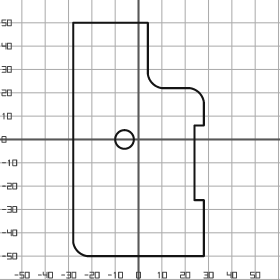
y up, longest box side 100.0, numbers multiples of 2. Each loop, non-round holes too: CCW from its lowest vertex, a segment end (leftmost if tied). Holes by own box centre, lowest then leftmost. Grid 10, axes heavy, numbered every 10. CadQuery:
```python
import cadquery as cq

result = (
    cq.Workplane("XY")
    .moveTo(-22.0, -50.0)
    .lineTo(28.0, -50.0)
    .lineTo(28.0, -26.0)
    .lineTo(24.0, -26.0)
    .lineTo(24.0, 6.0)
    .lineTo(28.0, 6.0)
    .lineTo(28.0, 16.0)
    .threePointArc((26.0, 20.0), (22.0, 22.0))
    .lineTo(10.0, 22.0)
    .threePointArc((6.0, 24.0), (4.0, 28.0))
    .lineTo(4.0, 50.0)
    .lineTo(-28.0, 50.0)
    .lineTo(-28.0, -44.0)
    .threePointArc((-26.0, -48.0), (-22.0, -50.0))
    .close()
    .moveTo(-6.0, 0.0)
    .circle(4.0)
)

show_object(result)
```